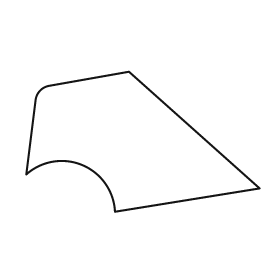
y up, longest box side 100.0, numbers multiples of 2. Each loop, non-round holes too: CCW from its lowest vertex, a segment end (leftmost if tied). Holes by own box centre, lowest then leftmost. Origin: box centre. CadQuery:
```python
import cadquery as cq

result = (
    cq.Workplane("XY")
    .moveTo(-12.0, -30.0)
    .lineTo(50.0, -20.0)
    .lineTo(-6.0, 30.0)
    .lineTo(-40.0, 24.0)
    .threePointArc((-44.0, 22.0), (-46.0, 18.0))
    .lineTo(-50.0, -14.0)
    .threePointArc((-26.0, -10.0), (-12.0, -30.0))
    .close()
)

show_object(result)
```